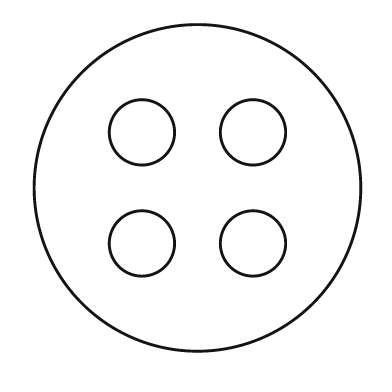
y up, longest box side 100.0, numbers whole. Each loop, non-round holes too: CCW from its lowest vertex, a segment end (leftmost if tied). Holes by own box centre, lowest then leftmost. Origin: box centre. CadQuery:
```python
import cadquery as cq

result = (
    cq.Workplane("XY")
    .moveTo(0.0, 0.0)
    .circle(50.0)
    .moveTo(-17.0, -17.0)
    .circle(10.0)
    .moveTo(17.0, -17.0)
    .circle(10.0)
    .moveTo(-17.0, 17.0)
    .circle(10.0)
    .moveTo(17.0, 17.0)
    .circle(10.0)
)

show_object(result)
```